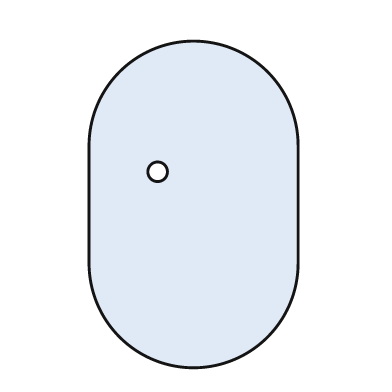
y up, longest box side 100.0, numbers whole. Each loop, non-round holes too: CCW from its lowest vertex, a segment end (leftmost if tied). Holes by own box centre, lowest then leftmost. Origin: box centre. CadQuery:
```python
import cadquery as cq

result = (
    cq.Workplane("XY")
    .moveTo(-32.0, -18.0)
    .threePointArc((0.0, -50.0), (32.0, -18.0))
    .lineTo(32.0, 18.0)
    .threePointArc((0.0, 50.0), (-32.0, 18.0))
    .close()
    .moveTo(-11.0, 10.0)
    .circle(3.0)
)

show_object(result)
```